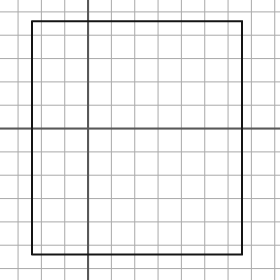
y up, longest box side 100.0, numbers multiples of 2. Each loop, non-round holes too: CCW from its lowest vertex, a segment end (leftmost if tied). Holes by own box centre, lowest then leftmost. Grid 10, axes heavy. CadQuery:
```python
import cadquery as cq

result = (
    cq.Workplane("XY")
    .moveTo(-24.0, -54.0)
    .lineTo(66.0, -54.0)
    .lineTo(66.0, 46.0)
    .lineTo(-24.0, 46.0)
    .close()
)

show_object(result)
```